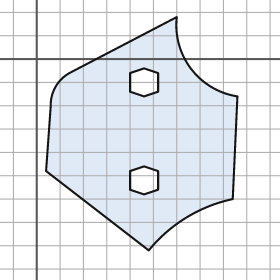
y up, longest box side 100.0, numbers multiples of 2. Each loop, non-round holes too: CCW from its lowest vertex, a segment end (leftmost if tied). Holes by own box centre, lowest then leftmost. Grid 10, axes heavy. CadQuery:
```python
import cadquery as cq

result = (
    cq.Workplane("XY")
    .moveTo(48.0, -82.0)
    .threePointArc((64.0, -68.0), (84.0, -60.0))
    .lineTo(86.0, -16.0)
    .threePointArc((66.0, -4.0), (60.0, 18.0))
    .lineTo(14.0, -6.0)
    .threePointArc((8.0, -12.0), (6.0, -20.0))
    .lineTo(4.0, -48.0)
    .close()
    .moveTo(46.0, -58.0)
    .lineTo(52.0, -56.0)
    .lineTo(52.0, -48.0)
    .lineTo(46.0, -46.0)
    .lineTo(40.0, -48.0)
    .lineTo(40.0, -56.0)
    .close()
    .moveTo(46.0, -16.0)
    .lineTo(52.0, -14.0)
    .lineTo(52.0, -6.0)
    .lineTo(46.0, -4.0)
    .lineTo(40.0, -6.0)
    .lineTo(40.0, -14.0)
    .close()
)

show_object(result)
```